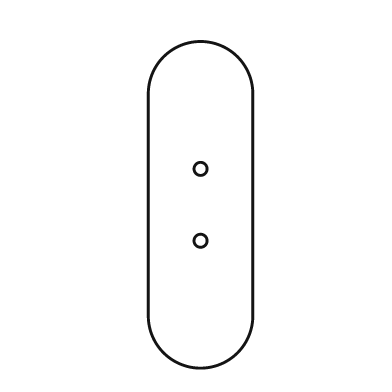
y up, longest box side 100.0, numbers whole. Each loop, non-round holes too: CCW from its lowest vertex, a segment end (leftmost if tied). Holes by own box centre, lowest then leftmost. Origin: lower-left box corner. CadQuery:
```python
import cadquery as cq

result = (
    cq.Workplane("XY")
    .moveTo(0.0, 16.0)
    .threePointArc((16.0, 0.0), (32.0, 16.0))
    .lineTo(32.0, 84.0)
    .threePointArc((16.0, 100.0), (0.0, 84.0))
    .close()
    .moveTo(16.0, 39.0)
    .circle(2.0)
    .moveTo(16.0, 61.0)
    .circle(2.0)
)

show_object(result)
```